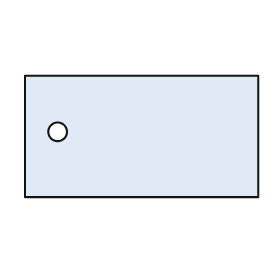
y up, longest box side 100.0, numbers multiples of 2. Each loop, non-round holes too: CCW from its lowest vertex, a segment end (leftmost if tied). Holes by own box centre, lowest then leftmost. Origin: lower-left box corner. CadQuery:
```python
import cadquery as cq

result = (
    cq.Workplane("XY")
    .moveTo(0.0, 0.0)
    .lineTo(100.0, 0.0)
    .lineTo(100.0, 52.0)
    .lineTo(0.0, 52.0)
    .close()
    .moveTo(14.0, 28.0)
    .circle(4.0)
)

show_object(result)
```